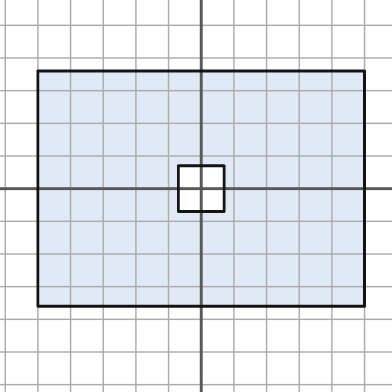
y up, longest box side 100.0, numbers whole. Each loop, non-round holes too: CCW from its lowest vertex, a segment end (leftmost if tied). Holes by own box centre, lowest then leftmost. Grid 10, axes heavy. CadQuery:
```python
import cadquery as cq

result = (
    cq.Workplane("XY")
    .moveTo(-50.0, -36.0)
    .lineTo(50.0, -36.0)
    .lineTo(50.0, 36.0)
    .lineTo(-50.0, 36.0)
    .close()
    .moveTo(-7.0, -7.0)
    .lineTo(7.0, -7.0)
    .lineTo(7.0, 7.0)
    .lineTo(-7.0, 7.0)
    .close()
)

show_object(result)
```